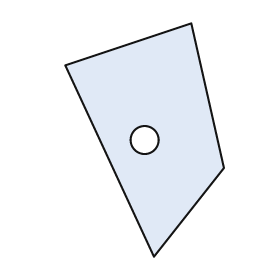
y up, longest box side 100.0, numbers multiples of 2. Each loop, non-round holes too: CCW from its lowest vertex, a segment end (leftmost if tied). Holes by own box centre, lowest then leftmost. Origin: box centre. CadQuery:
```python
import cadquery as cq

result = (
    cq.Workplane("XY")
    .moveTo(4.0, -50.0)
    .lineTo(34.0, -12.0)
    .lineTo(20.0, 50.0)
    .lineTo(-34.0, 32.0)
    .close()
    .moveTo(0.0, 0.0)
    .circle(6.0)
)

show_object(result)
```